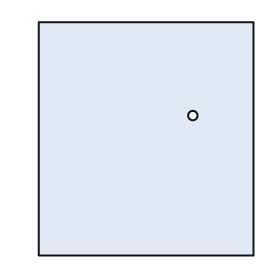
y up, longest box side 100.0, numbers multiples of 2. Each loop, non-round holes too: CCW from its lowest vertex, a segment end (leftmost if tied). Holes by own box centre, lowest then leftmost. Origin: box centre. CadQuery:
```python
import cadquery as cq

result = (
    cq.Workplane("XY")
    .moveTo(-46.0, -50.0)
    .lineTo(46.0, -50.0)
    .lineTo(46.0, 50.0)
    .lineTo(-46.0, 50.0)
    .close()
    .moveTo(20.0, 10.0)
    .circle(2.0)
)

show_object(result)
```